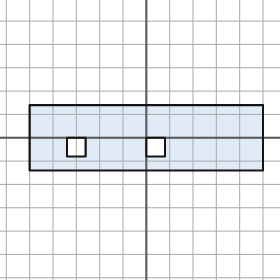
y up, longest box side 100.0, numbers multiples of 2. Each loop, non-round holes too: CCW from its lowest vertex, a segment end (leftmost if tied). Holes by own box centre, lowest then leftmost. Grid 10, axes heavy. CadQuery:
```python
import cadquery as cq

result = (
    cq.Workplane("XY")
    .moveTo(-50.0, -14.0)
    .lineTo(50.0, -14.0)
    .lineTo(50.0, 14.0)
    .lineTo(-50.0, 14.0)
    .close()
    .moveTo(-34.0, -8.0)
    .lineTo(-26.0, -8.0)
    .lineTo(-26.0, 0.0)
    .lineTo(-34.0, 0.0)
    .close()
    .moveTo(0.0, -8.0)
    .lineTo(8.0, -8.0)
    .lineTo(8.0, 0.0)
    .lineTo(0.0, 0.0)
    .close()
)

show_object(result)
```